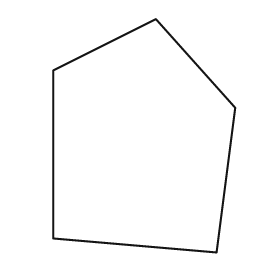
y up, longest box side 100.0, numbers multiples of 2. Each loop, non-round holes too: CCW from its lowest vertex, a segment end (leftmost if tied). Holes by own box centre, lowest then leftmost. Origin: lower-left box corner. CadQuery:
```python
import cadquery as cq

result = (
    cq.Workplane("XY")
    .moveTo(70.0, 0.0)
    .lineTo(78.0, 62.0)
    .lineTo(44.0, 100.0)
    .lineTo(0.0, 78.0)
    .lineTo(0.0, 6.0)
    .close()
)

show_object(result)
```